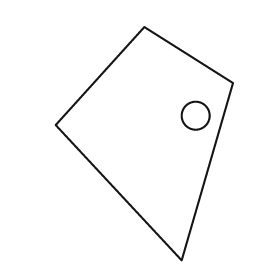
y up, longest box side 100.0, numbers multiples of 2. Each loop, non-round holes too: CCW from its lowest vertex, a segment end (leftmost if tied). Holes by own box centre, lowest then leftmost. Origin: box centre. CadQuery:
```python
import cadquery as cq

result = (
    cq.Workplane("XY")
    .moveTo(16.0, -50.0)
    .lineTo(38.0, 26.0)
    .lineTo(0.0, 50.0)
    .lineTo(-38.0, 8.0)
    .close()
    .moveTo(22.0, 12.0)
    .circle(6.0)
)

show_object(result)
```